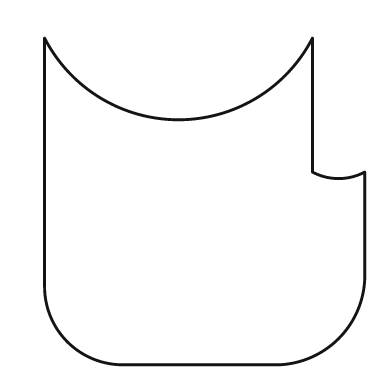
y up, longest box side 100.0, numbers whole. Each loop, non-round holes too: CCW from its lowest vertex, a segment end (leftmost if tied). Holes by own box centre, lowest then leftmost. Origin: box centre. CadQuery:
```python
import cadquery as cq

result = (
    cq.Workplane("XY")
    .moveTo(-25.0, -50.0)
    .lineTo(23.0, -50.0)
    .threePointArc((41.0, -42.0), (49.0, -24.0))
    .lineTo(49.0, 9.0)
    .threePointArc((41.0, 7.0), (33.0, 9.0))
    .lineTo(33.0, 50.0)
    .threePointArc((-8.0, 25.0), (-49.0, 50.0))
    .lineTo(-49.0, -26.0)
    .threePointArc((-42.0, -43.0), (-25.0, -50.0))
    .close()
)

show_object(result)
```